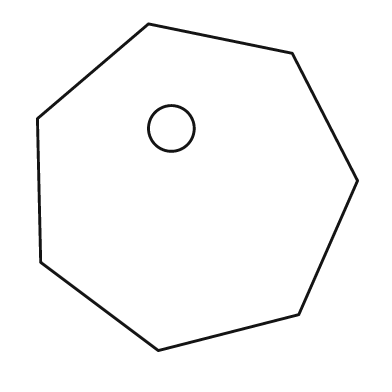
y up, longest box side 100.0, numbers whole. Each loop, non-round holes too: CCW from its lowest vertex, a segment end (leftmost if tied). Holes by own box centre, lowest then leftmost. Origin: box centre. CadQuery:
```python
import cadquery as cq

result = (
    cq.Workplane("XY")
    .moveTo(-12.0, -50.0)
    .lineTo(31.0, -39.0)
    .lineTo(49.0, 2.0)
    .lineTo(29.0, 41.0)
    .lineTo(-15.0, 50.0)
    .lineTo(-49.0, 21.0)
    .lineTo(-48.0, -23.0)
    .close()
    .moveTo(-8.0, 18.0)
    .circle(7.0)
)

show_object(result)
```